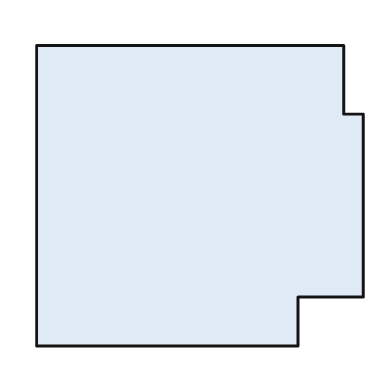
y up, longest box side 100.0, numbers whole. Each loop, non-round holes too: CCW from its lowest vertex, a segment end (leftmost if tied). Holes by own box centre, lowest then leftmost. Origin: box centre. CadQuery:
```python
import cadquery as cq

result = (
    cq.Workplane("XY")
    .moveTo(-50.0, -46.0)
    .lineTo(30.0, -46.0)
    .lineTo(30.0, -31.0)
    .lineTo(50.0, -31.0)
    .lineTo(50.0, 25.0)
    .lineTo(44.0, 25.0)
    .lineTo(44.0, 46.0)
    .lineTo(-50.0, 46.0)
    .close()
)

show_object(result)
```